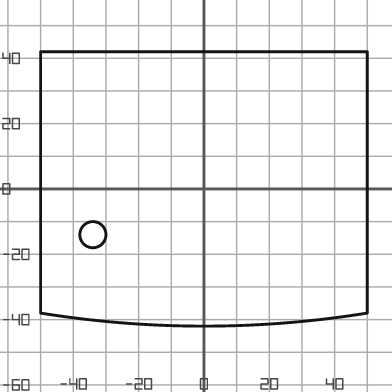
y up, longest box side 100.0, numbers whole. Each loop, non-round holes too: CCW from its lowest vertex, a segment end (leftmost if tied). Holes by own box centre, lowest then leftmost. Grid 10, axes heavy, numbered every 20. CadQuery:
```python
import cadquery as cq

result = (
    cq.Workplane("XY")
    .moveTo(-50.0, -38.0)
    .threePointArc((0.0, -42.0), (50.0, -38.0))
    .lineTo(50.0, 42.0)
    .lineTo(-50.0, 42.0)
    .close()
    .moveTo(-34.0, -14.0)
    .circle(4.0)
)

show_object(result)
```